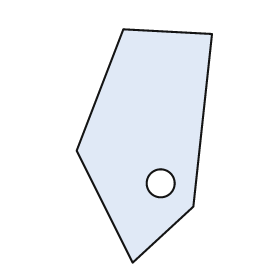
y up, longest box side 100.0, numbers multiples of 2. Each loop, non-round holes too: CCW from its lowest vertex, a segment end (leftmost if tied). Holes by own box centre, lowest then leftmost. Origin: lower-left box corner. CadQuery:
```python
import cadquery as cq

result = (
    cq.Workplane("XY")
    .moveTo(24.0, 0.0)
    .lineTo(50.0, 24.0)
    .lineTo(58.0, 98.0)
    .lineTo(20.0, 100.0)
    .lineTo(0.0, 48.0)
    .close()
    .moveTo(36.0, 34.0)
    .circle(6.0)
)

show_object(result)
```